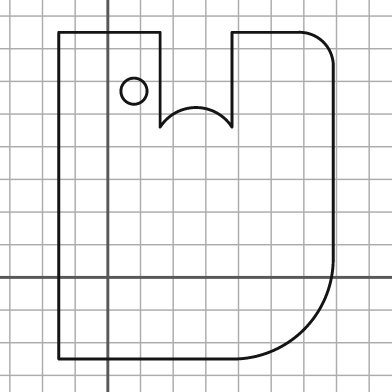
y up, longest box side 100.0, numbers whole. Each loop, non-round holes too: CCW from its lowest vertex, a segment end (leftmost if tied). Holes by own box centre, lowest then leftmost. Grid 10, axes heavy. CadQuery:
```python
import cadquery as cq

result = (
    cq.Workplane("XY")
    .moveTo(-15.0, -25.0)
    .lineTo(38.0, -25.0)
    .threePointArc((60.0, -16.0), (69.0, 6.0))
    .lineTo(69.0, 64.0)
    .threePointArc((66.0, 72.0), (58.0, 75.0))
    .lineTo(38.0, 75.0)
    .lineTo(38.0, 46.0)
    .threePointArc((27.0, 52.0), (16.0, 46.0))
    .lineTo(16.0, 75.0)
    .lineTo(-15.0, 75.0)
    .close()
    .moveTo(8.0, 57.0)
    .circle(4.0)
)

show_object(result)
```